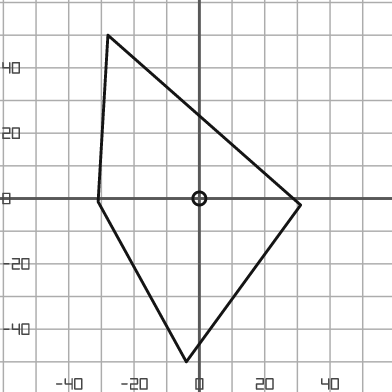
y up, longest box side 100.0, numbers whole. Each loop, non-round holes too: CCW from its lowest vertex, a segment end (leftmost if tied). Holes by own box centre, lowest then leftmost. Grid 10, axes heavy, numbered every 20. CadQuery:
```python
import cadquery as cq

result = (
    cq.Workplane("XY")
    .moveTo(-4.0, -50.0)
    .lineTo(31.0, -2.0)
    .lineTo(-28.0, 50.0)
    .lineTo(-31.0, -1.0)
    .close()
    .moveTo(0.0, 0.0)
    .circle(2.0)
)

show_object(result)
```